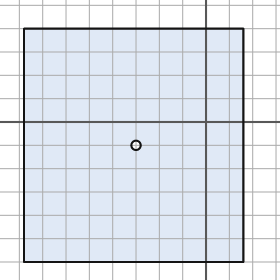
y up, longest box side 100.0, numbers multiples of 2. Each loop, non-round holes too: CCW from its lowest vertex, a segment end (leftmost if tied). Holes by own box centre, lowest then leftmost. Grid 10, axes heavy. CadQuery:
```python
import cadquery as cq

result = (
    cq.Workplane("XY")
    .moveTo(-78.0, -60.0)
    .lineTo(16.0, -60.0)
    .lineTo(16.0, 40.0)
    .lineTo(-78.0, 40.0)
    .close()
    .moveTo(-30.0, -10.0)
    .circle(2.0)
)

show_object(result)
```